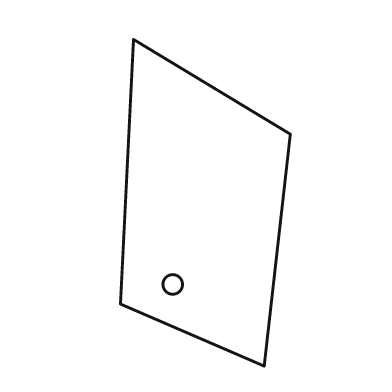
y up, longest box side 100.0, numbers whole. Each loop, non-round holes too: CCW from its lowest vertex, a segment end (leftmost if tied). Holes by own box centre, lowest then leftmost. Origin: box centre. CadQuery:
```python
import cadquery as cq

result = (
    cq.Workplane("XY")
    .moveTo(18.0, -50.0)
    .lineTo(26.0, 21.0)
    .lineTo(-22.0, 50.0)
    .lineTo(-26.0, -31.0)
    .close()
    .moveTo(-10.0, -25.0)
    .circle(3.0)
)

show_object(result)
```